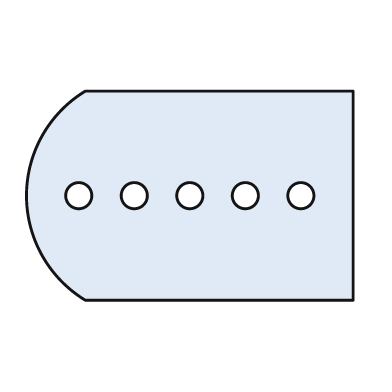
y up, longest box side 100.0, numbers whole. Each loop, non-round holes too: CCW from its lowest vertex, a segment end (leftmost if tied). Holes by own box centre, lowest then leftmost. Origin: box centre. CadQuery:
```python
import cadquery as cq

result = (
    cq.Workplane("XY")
    .moveTo(-32.0, -32.0)
    .lineTo(50.0, -32.0)
    .lineTo(50.0, 32.0)
    .lineTo(-32.0, 32.0)
    .threePointArc((-50.0, 0.0), (-32.0, -32.0))
    .close()
    .moveTo(-34.0, 0.0)
    .circle(4.0)
    .moveTo(-17.0, 0.0)
    .circle(4.0)
    .moveTo(0.0, 0.0)
    .circle(4.0)
    .moveTo(17.0, 0.0)
    .circle(4.0)
    .moveTo(34.0, 0.0)
    .circle(4.0)
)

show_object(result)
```